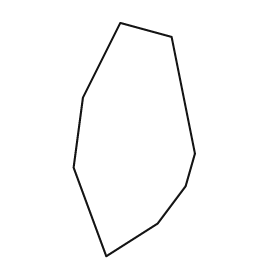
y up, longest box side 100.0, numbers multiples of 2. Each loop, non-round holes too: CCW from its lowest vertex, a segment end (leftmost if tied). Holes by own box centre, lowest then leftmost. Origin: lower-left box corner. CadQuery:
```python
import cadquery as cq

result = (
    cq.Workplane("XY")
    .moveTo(14.0, 0.0)
    .lineTo(36.0, 14.0)
    .lineTo(48.0, 30.0)
    .lineTo(52.0, 44.0)
    .lineTo(42.0, 94.0)
    .lineTo(20.0, 100.0)
    .lineTo(4.0, 68.0)
    .lineTo(0.0, 38.0)
    .close()
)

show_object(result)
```